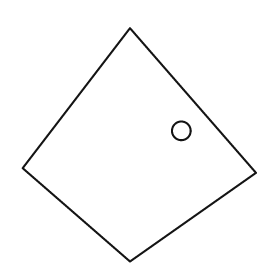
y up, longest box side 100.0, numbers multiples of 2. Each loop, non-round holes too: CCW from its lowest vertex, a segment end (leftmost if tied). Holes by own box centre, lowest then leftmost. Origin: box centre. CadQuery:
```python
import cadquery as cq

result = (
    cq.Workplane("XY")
    .moveTo(-4.0, -50.0)
    .lineTo(50.0, -12.0)
    .lineTo(-4.0, 50.0)
    .lineTo(-50.0, -10.0)
    .close()
    .moveTo(18.0, 6.0)
    .circle(4.0)
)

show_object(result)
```